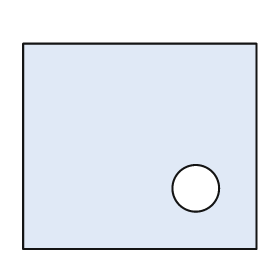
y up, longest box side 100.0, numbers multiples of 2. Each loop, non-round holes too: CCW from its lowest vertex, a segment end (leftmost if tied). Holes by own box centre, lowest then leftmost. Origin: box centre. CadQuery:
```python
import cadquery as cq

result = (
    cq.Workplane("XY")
    .moveTo(-50.0, -44.0)
    .lineTo(50.0, -44.0)
    .lineTo(50.0, 44.0)
    .lineTo(-50.0, 44.0)
    .close()
    .moveTo(24.0, -18.0)
    .circle(10.0)
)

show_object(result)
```